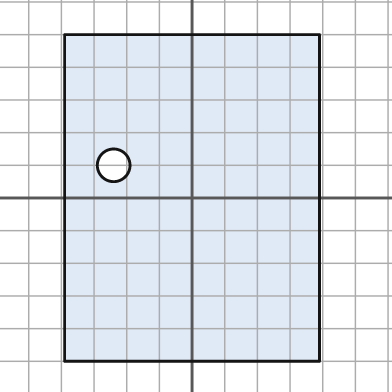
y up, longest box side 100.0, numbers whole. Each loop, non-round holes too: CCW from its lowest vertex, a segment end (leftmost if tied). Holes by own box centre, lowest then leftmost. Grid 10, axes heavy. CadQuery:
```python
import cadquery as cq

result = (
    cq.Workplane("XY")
    .moveTo(-39.0, -50.0)
    .lineTo(39.0, -50.0)
    .lineTo(39.0, 50.0)
    .lineTo(-39.0, 50.0)
    .close()
    .moveTo(-24.0, 10.0)
    .circle(5.0)
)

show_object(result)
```